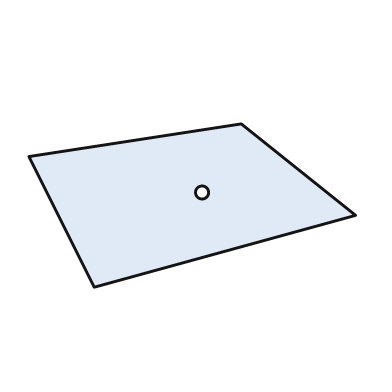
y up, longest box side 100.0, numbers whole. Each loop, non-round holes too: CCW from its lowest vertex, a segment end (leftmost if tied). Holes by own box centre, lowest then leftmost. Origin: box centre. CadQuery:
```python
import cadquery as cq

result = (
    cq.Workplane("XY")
    .moveTo(-30.0, -25.0)
    .lineTo(50.0, -3.0)
    .lineTo(15.0, 25.0)
    .lineTo(-50.0, 15.0)
    .close()
    .moveTo(3.0, 4.0)
    .circle(2.0)
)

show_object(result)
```